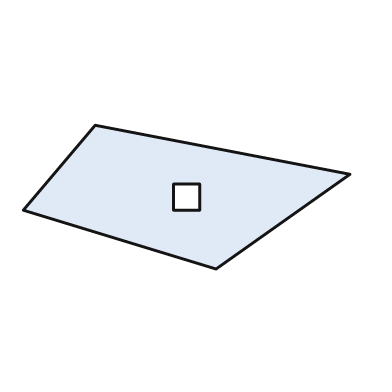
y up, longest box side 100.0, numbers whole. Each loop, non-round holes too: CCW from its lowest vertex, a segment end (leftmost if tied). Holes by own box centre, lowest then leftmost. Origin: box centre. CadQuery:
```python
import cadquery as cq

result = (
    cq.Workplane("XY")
    .moveTo(9.0, -22.0)
    .lineTo(50.0, 7.0)
    .lineTo(-28.0, 22.0)
    .lineTo(-50.0, -4.0)
    .close()
    .moveTo(-4.0, -4.0)
    .lineTo(4.0, -4.0)
    .lineTo(4.0, 4.0)
    .lineTo(-4.0, 4.0)
    .close()
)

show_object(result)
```